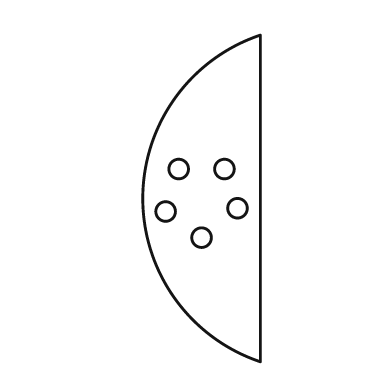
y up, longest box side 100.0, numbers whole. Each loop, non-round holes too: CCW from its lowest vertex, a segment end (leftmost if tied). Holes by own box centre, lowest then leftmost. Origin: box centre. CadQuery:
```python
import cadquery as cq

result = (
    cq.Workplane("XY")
    .moveTo(18.0, -50.0)
    .lineTo(18.0, 50.0)
    .threePointArc((-18.0, 0.0), (18.0, -50.0))
    .close()
    .moveTo(0.0, -12.0)
    .circle(3.0)
    .moveTo(-11.0, -4.0)
    .circle(3.0)
    .moveTo(11.0, -3.0)
    .circle(3.0)
    .moveTo(-7.0, 9.0)
    .circle(3.0)
    .moveTo(7.0, 9.0)
    .circle(3.0)
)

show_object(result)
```